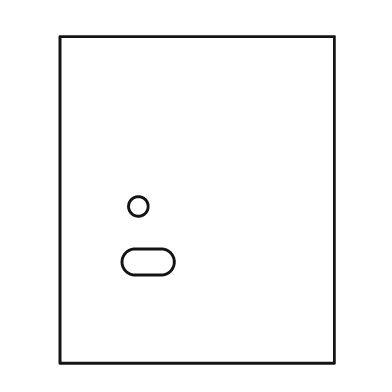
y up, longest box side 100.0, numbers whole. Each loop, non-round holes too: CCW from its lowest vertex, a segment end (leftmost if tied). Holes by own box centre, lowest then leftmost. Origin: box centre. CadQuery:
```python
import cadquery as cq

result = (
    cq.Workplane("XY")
    .moveTo(-42.0, -50.0)
    .lineTo(42.0, -50.0)
    .lineTo(42.0, 50.0)
    .lineTo(-42.0, 50.0)
    .close()
    .moveTo(-19.0, -23.0)
    .lineTo(-11.0, -23.0)
    .threePointArc((-7.0, -19.0), (-11.0, -15.0))
    .lineTo(-19.0, -15.0)
    .threePointArc((-23.0, -19.0), (-19.0, -23.0))
    .close()
    .moveTo(-18.0, -2.0)
    .circle(3.0)
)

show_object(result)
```